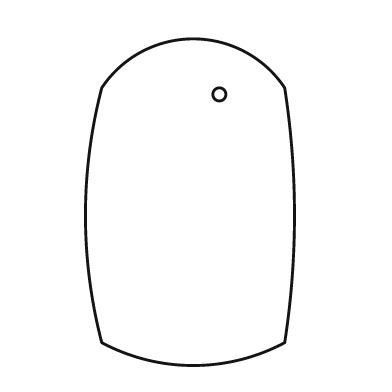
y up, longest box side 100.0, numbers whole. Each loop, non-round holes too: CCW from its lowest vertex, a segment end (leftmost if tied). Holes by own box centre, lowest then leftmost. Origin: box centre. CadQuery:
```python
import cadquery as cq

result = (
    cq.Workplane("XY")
    .moveTo(-27.0, -43.0)
    .threePointArc((1.0, -50.0), (29.0, -43.0))
    .threePointArc((32.0, -4.0), (29.0, 35.0))
    .threePointArc((1.0, 50.0), (-27.0, 35.0))
    .threePointArc((-32.0, -4.0), (-27.0, -43.0))
    .close()
    .moveTo(9.0, 33.0)
    .circle(2.0)
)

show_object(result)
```